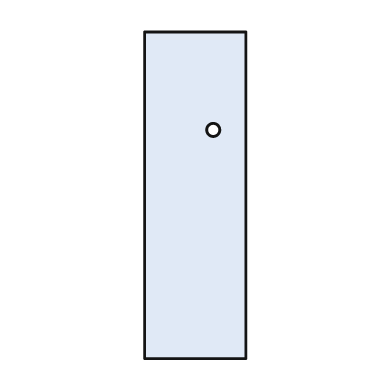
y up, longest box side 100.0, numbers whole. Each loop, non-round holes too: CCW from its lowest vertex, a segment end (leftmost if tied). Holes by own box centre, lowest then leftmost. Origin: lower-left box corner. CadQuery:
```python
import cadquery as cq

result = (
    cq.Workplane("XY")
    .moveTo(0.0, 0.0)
    .lineTo(31.0, 0.0)
    .lineTo(31.0, 100.0)
    .lineTo(0.0, 100.0)
    .close()
    .moveTo(21.0, 70.0)
    .circle(2.0)
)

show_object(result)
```